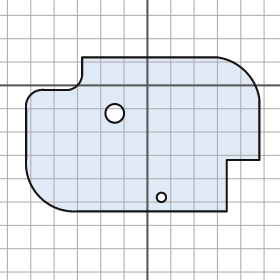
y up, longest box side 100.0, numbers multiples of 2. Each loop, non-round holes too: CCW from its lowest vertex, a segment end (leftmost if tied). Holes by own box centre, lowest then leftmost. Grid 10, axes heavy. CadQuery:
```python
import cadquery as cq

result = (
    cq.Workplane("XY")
    .moveTo(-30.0, -54.0)
    .lineTo(34.0, -54.0)
    .lineTo(34.0, -32.0)
    .lineTo(48.0, -32.0)
    .lineTo(48.0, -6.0)
    .threePointArc((42.0, 6.0), (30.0, 12.0))
    .lineTo(-28.0, 12.0)
    .lineTo(-28.0, 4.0)
    .threePointArc((-30.0, 0.0), (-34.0, -2.0))
    .lineTo(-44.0, -2.0)
    .threePointArc((-50.0, -4.0), (-52.0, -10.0))
    .lineTo(-52.0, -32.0)
    .threePointArc((-46.0, -48.0), (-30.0, -54.0))
    .close()
    .moveTo(6.0, -48.0)
    .circle(2.0)
    .moveTo(-14.0, -12.0)
    .circle(4.0)
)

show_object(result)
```